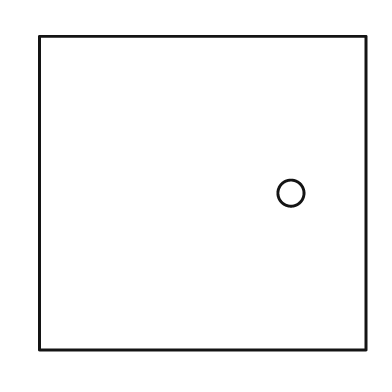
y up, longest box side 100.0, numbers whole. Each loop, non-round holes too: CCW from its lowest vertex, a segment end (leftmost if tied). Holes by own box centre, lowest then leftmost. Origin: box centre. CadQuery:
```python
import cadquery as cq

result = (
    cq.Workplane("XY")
    .moveTo(-50.0, -48.0)
    .lineTo(50.0, -48.0)
    .lineTo(50.0, 48.0)
    .lineTo(-50.0, 48.0)
    .close()
    .moveTo(27.0, 0.0)
    .circle(4.0)
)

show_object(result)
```